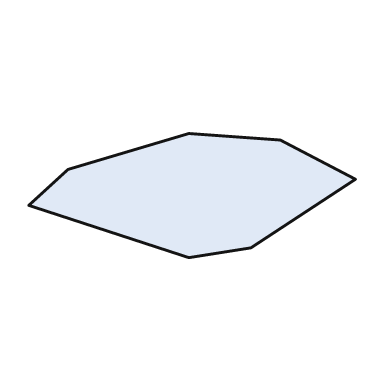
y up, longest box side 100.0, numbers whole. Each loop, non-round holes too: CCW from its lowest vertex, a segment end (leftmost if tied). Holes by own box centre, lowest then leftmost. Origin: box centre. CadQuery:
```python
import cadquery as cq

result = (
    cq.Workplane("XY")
    .moveTo(-1.0, -19.0)
    .lineTo(18.0, -16.0)
    .lineTo(50.0, 5.0)
    .lineTo(27.0, 17.0)
    .lineTo(-1.0, 19.0)
    .lineTo(-38.0, 8.0)
    .lineTo(-50.0, -3.0)
    .close()
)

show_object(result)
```